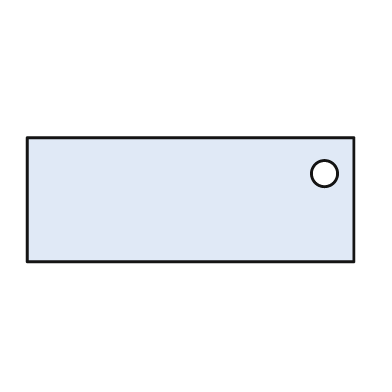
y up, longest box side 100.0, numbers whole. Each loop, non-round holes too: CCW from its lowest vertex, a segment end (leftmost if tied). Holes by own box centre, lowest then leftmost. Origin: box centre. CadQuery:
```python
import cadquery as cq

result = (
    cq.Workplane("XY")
    .moveTo(-50.0, -19.0)
    .lineTo(50.0, -19.0)
    .lineTo(50.0, 19.0)
    .lineTo(-50.0, 19.0)
    .close()
    .moveTo(41.0, 8.0)
    .circle(4.0)
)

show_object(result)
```